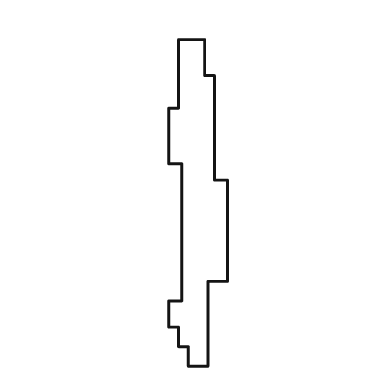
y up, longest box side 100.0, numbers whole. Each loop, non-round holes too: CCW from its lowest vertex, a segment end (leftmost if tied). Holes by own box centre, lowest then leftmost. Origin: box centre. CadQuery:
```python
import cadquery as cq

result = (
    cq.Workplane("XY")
    .moveTo(-3.0, -50.0)
    .lineTo(3.0, -50.0)
    .lineTo(3.0, -24.0)
    .lineTo(9.0, -24.0)
    .lineTo(9.0, 7.0)
    .lineTo(5.0, 7.0)
    .lineTo(5.0, 39.0)
    .lineTo(2.0, 39.0)
    .lineTo(2.0, 50.0)
    .lineTo(-6.0, 50.0)
    .lineTo(-6.0, 29.0)
    .lineTo(-9.0, 29.0)
    .lineTo(-9.0, 12.0)
    .lineTo(-5.0, 12.0)
    .lineTo(-5.0, -30.0)
    .lineTo(-9.0, -30.0)
    .lineTo(-9.0, -38.0)
    .lineTo(-6.0, -38.0)
    .lineTo(-6.0, -44.0)
    .lineTo(-3.0, -44.0)
    .close()
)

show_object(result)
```